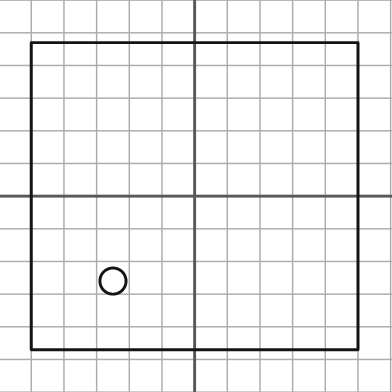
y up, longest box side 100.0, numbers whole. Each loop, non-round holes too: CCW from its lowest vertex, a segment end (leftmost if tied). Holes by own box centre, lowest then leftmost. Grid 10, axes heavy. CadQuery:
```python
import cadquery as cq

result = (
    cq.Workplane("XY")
    .moveTo(-50.0, -47.0)
    .lineTo(50.0, -47.0)
    .lineTo(50.0, 47.0)
    .lineTo(-50.0, 47.0)
    .close()
    .moveTo(-25.0, -26.0)
    .circle(4.0)
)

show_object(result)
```